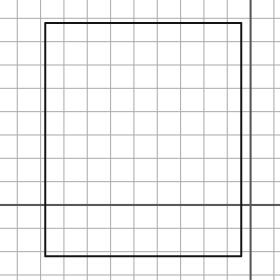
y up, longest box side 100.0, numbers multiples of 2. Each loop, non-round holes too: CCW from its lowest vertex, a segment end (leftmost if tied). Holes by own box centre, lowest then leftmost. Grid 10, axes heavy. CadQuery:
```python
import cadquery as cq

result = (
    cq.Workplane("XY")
    .moveTo(-88.0, -22.0)
    .lineTo(-4.0, -22.0)
    .lineTo(-4.0, 78.0)
    .lineTo(-88.0, 78.0)
    .close()
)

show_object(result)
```